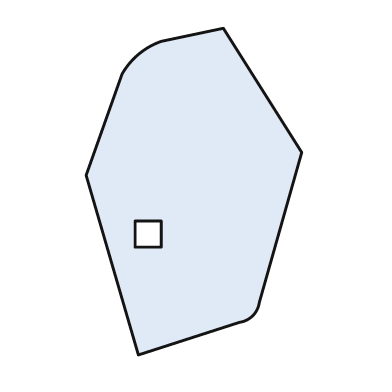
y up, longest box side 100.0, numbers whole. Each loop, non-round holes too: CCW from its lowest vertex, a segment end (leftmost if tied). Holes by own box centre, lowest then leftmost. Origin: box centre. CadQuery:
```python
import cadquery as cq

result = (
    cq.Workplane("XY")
    .moveTo(-17.0, -50.0)
    .lineTo(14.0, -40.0)
    .threePointArc((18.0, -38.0), (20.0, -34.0))
    .lineTo(33.0, 12.0)
    .lineTo(9.0, 50.0)
    .lineTo(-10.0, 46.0)
    .threePointArc((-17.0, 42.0), (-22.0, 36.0))
    .lineTo(-33.0, 5.0)
    .close()
    .moveTo(-18.0, -17.0)
    .lineTo(-10.0, -17.0)
    .lineTo(-10.0, -9.0)
    .lineTo(-18.0, -9.0)
    .close()
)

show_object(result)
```